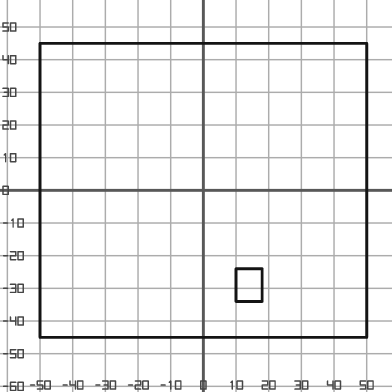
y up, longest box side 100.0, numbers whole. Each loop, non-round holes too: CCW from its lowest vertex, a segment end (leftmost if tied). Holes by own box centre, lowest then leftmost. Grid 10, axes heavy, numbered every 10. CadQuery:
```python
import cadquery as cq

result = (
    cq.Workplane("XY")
    .moveTo(-50.0, -45.0)
    .lineTo(50.0, -45.0)
    .lineTo(50.0, 45.0)
    .lineTo(-50.0, 45.0)
    .close()
    .moveTo(10.0, -34.0)
    .lineTo(18.0, -34.0)
    .lineTo(18.0, -24.0)
    .lineTo(10.0, -24.0)
    .close()
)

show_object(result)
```